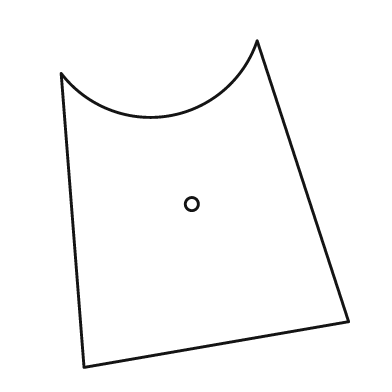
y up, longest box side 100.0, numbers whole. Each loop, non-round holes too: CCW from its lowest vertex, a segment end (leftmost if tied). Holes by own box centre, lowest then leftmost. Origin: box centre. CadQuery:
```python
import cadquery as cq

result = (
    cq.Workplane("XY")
    .moveTo(-37.0, -50.0)
    .lineTo(44.0, -36.0)
    .lineTo(16.0, 50.0)
    .threePointArc((-11.0, 27.0), (-44.0, 40.0))
    .close()
    .moveTo(-4.0, 0.0)
    .circle(2.0)
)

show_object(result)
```